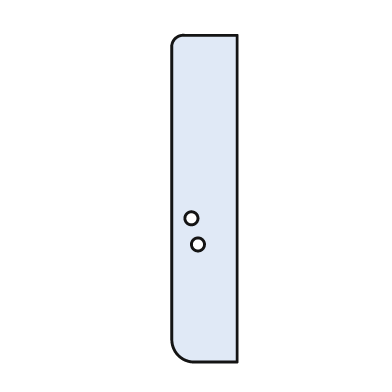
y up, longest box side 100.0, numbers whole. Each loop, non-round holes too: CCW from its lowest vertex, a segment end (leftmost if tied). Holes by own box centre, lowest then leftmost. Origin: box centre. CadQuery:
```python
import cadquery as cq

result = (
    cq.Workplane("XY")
    .moveTo(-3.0, -50.0)
    .lineTo(10.0, -50.0)
    .lineTo(10.0, 50.0)
    .lineTo(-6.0, 50.0)
    .threePointArc((-9.0, 49.0), (-10.0, 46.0))
    .lineTo(-10.0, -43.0)
    .threePointArc((-8.0, -48.0), (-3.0, -50.0))
    .close()
    .moveTo(-2.0, -14.0)
    .circle(2.0)
    .moveTo(-4.0, -6.0)
    .circle(2.0)
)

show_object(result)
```